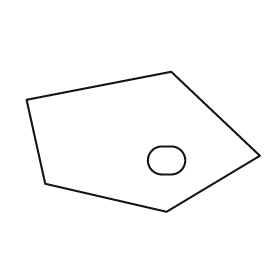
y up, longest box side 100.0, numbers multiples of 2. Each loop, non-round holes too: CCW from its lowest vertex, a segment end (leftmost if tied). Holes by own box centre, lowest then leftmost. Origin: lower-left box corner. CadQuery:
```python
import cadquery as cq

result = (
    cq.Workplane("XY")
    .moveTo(60.0, 0.0)
    .lineTo(100.0, 24.0)
    .lineTo(62.0, 60.0)
    .lineTo(0.0, 48.0)
    .lineTo(8.0, 12.0)
    .close()
    .moveTo(58.0, 16.0)
    .lineTo(62.0, 16.0)
    .threePointArc((68.0, 22.0), (62.0, 28.0))
    .lineTo(58.0, 28.0)
    .threePointArc((52.0, 22.0), (58.0, 16.0))
    .close()
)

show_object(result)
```